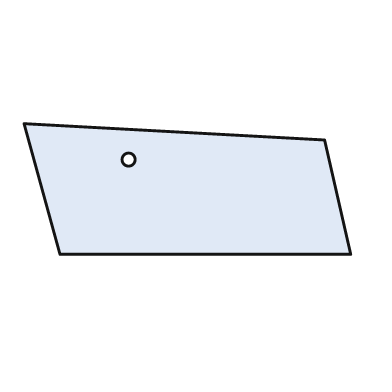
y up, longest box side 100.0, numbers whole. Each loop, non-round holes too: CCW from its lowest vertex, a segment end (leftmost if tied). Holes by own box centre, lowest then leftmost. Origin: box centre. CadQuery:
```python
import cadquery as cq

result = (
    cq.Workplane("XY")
    .moveTo(-39.0, -20.0)
    .lineTo(50.0, -20.0)
    .lineTo(42.0, 15.0)
    .lineTo(-50.0, 20.0)
    .close()
    .moveTo(-18.0, 9.0)
    .circle(2.0)
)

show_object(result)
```